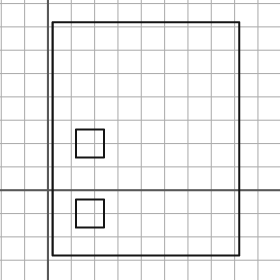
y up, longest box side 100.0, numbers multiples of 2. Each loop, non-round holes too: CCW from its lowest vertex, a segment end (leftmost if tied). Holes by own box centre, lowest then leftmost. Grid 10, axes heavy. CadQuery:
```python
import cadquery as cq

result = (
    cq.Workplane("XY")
    .moveTo(2.0, -28.0)
    .lineTo(82.0, -28.0)
    .lineTo(82.0, 72.0)
    .lineTo(2.0, 72.0)
    .close()
    .moveTo(12.0, -16.0)
    .lineTo(24.0, -16.0)
    .lineTo(24.0, -4.0)
    .lineTo(12.0, -4.0)
    .close()
    .moveTo(12.0, 14.0)
    .lineTo(24.0, 14.0)
    .lineTo(24.0, 26.0)
    .lineTo(12.0, 26.0)
    .close()
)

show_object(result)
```